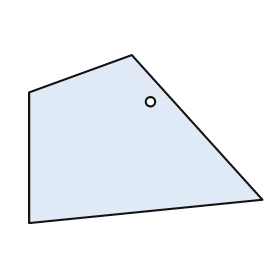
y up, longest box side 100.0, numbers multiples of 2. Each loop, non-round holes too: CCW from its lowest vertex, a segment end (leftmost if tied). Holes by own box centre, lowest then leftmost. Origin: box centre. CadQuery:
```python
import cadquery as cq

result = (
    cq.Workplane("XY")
    .moveTo(-50.0, -36.0)
    .lineTo(50.0, -26.0)
    .lineTo(-6.0, 36.0)
    .lineTo(-50.0, 20.0)
    .close()
    .moveTo(2.0, 16.0)
    .circle(2.0)
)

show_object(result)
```